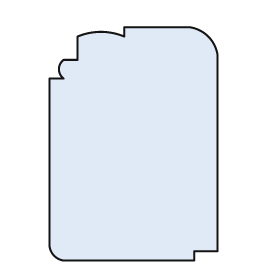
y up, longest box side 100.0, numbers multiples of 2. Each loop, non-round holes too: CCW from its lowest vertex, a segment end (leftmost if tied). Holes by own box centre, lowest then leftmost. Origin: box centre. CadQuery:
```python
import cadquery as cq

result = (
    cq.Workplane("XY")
    .moveTo(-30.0, -50.0)
    .lineTo(26.0, -50.0)
    .lineTo(26.0, -46.0)
    .lineTo(36.0, -46.0)
    .lineTo(36.0, 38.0)
    .threePointArc((32.0, 46.0), (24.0, 50.0))
    .lineTo(-4.0, 50.0)
    .lineTo(-4.0, 46.0)
    .threePointArc((-14.0, 48.0), (-24.0, 46.0))
    .lineTo(-24.0, 36.0)
    .lineTo(-30.0, 36.0)
    .threePointArc((-32.0, 32.0), (-30.0, 28.0))
    .lineTo(-36.0, 28.0)
    .lineTo(-36.0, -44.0)
    .threePointArc((-34.0, -48.0), (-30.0, -50.0))
    .close()
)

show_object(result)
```